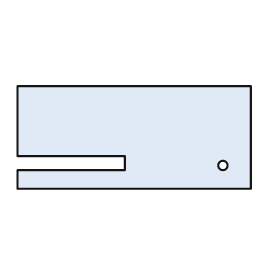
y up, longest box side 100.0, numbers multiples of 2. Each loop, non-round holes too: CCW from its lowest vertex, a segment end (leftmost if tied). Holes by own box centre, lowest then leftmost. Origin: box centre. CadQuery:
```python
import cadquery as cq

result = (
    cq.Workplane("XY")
    .moveTo(-50.0, -22.0)
    .lineTo(50.0, -22.0)
    .lineTo(50.0, 22.0)
    .lineTo(-50.0, 22.0)
    .lineTo(-50.0, -8.0)
    .lineTo(-4.0, -8.0)
    .lineTo(-4.0, -14.0)
    .lineTo(-50.0, -14.0)
    .close()
    .moveTo(38.0, -12.0)
    .circle(2.0)
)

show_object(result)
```